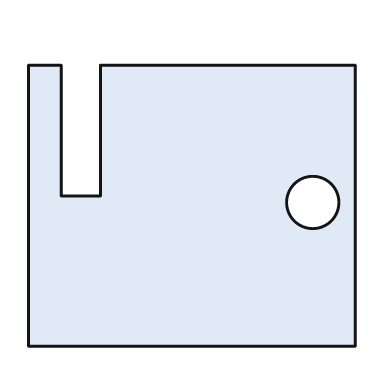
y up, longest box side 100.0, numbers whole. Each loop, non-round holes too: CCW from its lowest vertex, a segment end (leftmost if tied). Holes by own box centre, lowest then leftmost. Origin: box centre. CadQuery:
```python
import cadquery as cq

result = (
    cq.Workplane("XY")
    .moveTo(-50.0, -43.0)
    .lineTo(50.0, -43.0)
    .lineTo(50.0, 43.0)
    .lineTo(-28.0, 43.0)
    .lineTo(-28.0, 3.0)
    .lineTo(-40.0, 3.0)
    .lineTo(-40.0, 43.0)
    .lineTo(-50.0, 43.0)
    .close()
    .moveTo(37.0, 1.0)
    .circle(8.0)
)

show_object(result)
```